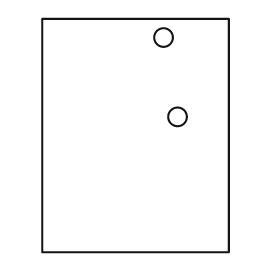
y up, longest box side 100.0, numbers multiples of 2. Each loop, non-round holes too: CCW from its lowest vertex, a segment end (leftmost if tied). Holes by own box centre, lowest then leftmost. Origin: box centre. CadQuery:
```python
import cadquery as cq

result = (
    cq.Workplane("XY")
    .moveTo(-40.0, -50.0)
    .lineTo(40.0, -50.0)
    .lineTo(40.0, 50.0)
    .lineTo(-40.0, 50.0)
    .close()
    .moveTo(18.0, 8.0)
    .circle(4.0)
    .moveTo(12.0, 42.0)
    .circle(4.0)
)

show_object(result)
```